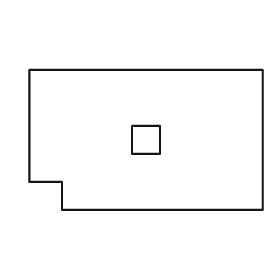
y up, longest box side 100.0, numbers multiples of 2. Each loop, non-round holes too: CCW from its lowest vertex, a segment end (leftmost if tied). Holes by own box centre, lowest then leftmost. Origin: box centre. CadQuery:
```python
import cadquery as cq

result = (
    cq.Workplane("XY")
    .moveTo(-36.0, -30.0)
    .lineTo(50.0, -30.0)
    .lineTo(50.0, 30.0)
    .lineTo(-50.0, 30.0)
    .lineTo(-50.0, -18.0)
    .lineTo(-36.0, -18.0)
    .close()
    .moveTo(-6.0, -6.0)
    .lineTo(6.0, -6.0)
    .lineTo(6.0, 6.0)
    .lineTo(-6.0, 6.0)
    .close()
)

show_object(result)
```